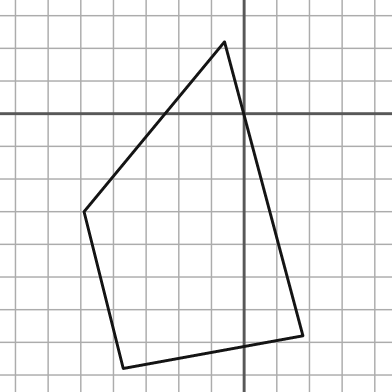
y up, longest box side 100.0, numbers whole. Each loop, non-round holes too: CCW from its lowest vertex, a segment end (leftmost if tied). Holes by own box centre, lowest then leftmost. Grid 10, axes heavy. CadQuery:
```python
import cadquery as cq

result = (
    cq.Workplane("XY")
    .moveTo(-37.0, -78.0)
    .lineTo(18.0, -68.0)
    .lineTo(-6.0, 22.0)
    .lineTo(-49.0, -30.0)
    .close()
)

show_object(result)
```